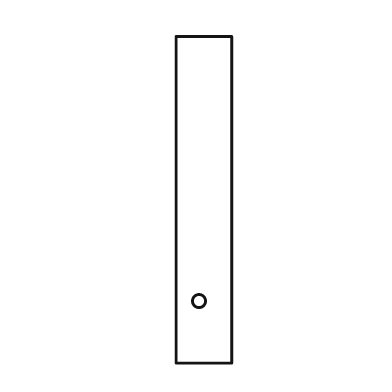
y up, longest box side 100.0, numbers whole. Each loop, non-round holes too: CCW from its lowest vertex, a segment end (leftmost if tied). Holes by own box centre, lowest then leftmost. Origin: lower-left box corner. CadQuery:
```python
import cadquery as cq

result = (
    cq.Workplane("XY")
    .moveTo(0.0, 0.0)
    .lineTo(17.0, 0.0)
    .lineTo(17.0, 100.0)
    .lineTo(0.0, 100.0)
    .close()
    .moveTo(7.0, 19.0)
    .circle(2.0)
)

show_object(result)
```